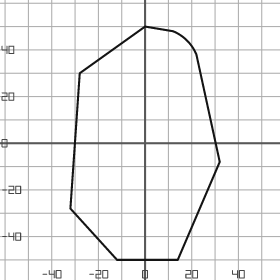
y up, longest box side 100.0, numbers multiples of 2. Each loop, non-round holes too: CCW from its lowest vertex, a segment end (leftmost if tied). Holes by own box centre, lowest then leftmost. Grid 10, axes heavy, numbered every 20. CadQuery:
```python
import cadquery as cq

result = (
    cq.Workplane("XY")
    .moveTo(-12.0, -50.0)
    .lineTo(14.0, -50.0)
    .lineTo(32.0, -8.0)
    .lineTo(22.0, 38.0)
    .threePointArc((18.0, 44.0), (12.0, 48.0))
    .lineTo(0.0, 50.0)
    .lineTo(-28.0, 30.0)
    .lineTo(-32.0, -28.0)
    .close()
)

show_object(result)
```